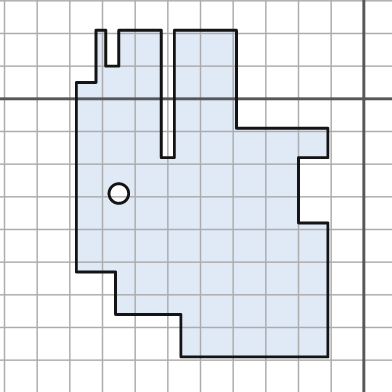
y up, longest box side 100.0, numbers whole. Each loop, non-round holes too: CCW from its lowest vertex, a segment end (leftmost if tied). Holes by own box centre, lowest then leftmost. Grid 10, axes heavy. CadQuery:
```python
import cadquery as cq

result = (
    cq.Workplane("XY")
    .moveTo(-56.0, -79.0)
    .lineTo(-11.0, -79.0)
    .lineTo(-11.0, -38.0)
    .lineTo(-20.0, -38.0)
    .lineTo(-20.0, -18.0)
    .lineTo(-11.0, -18.0)
    .lineTo(-11.0, -9.0)
    .lineTo(-39.0, -9.0)
    .lineTo(-39.0, 21.0)
    .lineTo(-58.0, 21.0)
    .lineTo(-58.0, -18.0)
    .lineTo(-62.0, -18.0)
    .lineTo(-62.0, 21.0)
    .lineTo(-75.0, 21.0)
    .lineTo(-75.0, 10.0)
    .lineTo(-79.0, 10.0)
    .lineTo(-79.0, 21.0)
    .lineTo(-82.0, 21.0)
    .lineTo(-82.0, 5.0)
    .lineTo(-88.0, 5.0)
    .lineTo(-88.0, -53.0)
    .lineTo(-76.0, -53.0)
    .lineTo(-76.0, -66.0)
    .lineTo(-56.0, -66.0)
    .close()
    .moveTo(-75.0, -29.0)
    .circle(3.0)
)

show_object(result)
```